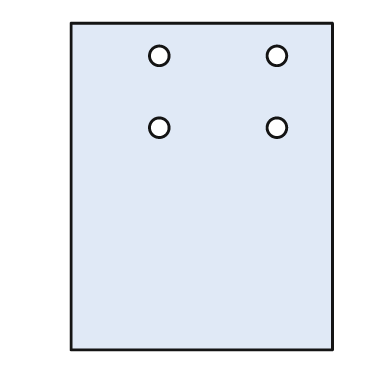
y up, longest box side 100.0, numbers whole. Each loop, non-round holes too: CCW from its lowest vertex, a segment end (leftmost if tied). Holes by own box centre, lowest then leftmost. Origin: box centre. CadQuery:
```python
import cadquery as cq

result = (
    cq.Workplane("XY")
    .moveTo(-40.0, -50.0)
    .lineTo(40.0, -50.0)
    .lineTo(40.0, 50.0)
    .lineTo(-40.0, 50.0)
    .close()
    .moveTo(-13.0, 18.0)
    .circle(3.0)
    .moveTo(23.0, 18.0)
    .circle(3.0)
    .moveTo(-13.0, 40.0)
    .circle(3.0)
    .moveTo(23.0, 40.0)
    .circle(3.0)
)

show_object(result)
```